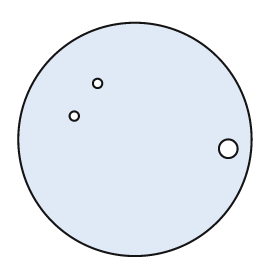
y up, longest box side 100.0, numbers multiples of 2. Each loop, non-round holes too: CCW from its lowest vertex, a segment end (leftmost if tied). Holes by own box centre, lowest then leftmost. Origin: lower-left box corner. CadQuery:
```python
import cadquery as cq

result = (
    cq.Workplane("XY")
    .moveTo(50.0, 50.0)
    .circle(50.0)
    .moveTo(90.0, 46.0)
    .circle(4.0)
    .moveTo(24.0, 60.0)
    .circle(2.0)
    .moveTo(34.0, 74.0)
    .circle(2.0)
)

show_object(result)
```